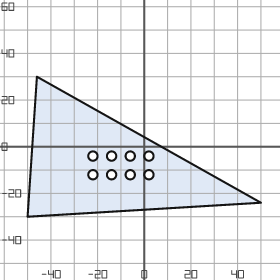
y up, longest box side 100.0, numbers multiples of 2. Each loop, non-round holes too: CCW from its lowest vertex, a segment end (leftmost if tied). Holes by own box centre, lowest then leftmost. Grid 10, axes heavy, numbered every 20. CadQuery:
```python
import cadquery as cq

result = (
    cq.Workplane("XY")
    .moveTo(-50.0, -30.0)
    .lineTo(50.0, -24.0)
    .lineTo(-46.0, 30.0)
    .close()
    .moveTo(-22.0, -12.0)
    .circle(2.0)
    .moveTo(-14.0, -12.0)
    .circle(2.0)
    .moveTo(-6.0, -12.0)
    .circle(2.0)
    .moveTo(2.0, -12.0)
    .circle(2.0)
    .moveTo(-22.0, -4.0)
    .circle(2.0)
    .moveTo(-14.0, -4.0)
    .circle(2.0)
    .moveTo(-6.0, -4.0)
    .circle(2.0)
    .moveTo(2.0, -4.0)
    .circle(2.0)
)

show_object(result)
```